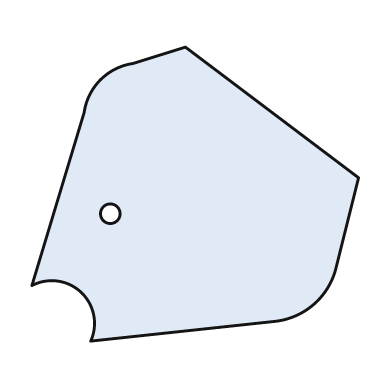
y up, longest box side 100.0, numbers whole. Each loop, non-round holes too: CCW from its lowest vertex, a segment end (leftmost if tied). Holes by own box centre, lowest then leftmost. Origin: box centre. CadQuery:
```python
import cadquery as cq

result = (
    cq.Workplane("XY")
    .moveTo(-32.0, -45.0)
    .lineTo(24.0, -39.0)
    .threePointArc((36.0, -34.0), (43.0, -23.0))
    .lineTo(50.0, 5.0)
    .lineTo(-3.0, 45.0)
    .lineTo(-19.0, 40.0)
    .threePointArc((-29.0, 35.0), (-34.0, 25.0))
    .lineTo(-50.0, -28.0)
    .threePointArc((-35.0, -30.0), (-32.0, -45.0))
    .close()
    .moveTo(-26.0, -6.0)
    .circle(3.0)
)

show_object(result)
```